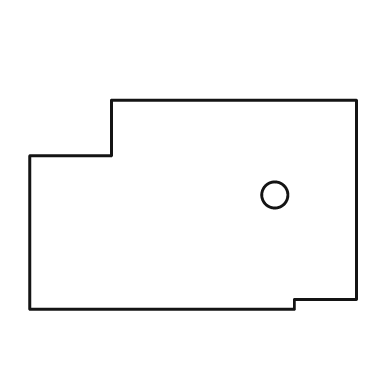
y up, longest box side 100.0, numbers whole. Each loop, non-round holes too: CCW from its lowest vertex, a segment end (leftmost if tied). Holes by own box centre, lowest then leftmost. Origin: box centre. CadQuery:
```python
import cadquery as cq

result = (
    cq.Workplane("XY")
    .moveTo(-50.0, -32.0)
    .lineTo(31.0, -32.0)
    .lineTo(31.0, -29.0)
    .lineTo(50.0, -29.0)
    .lineTo(50.0, 32.0)
    .lineTo(-25.0, 32.0)
    .lineTo(-25.0, 15.0)
    .lineTo(-50.0, 15.0)
    .close()
    .moveTo(25.0, 3.0)
    .circle(4.0)
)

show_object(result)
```